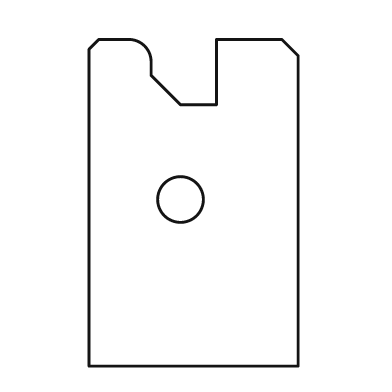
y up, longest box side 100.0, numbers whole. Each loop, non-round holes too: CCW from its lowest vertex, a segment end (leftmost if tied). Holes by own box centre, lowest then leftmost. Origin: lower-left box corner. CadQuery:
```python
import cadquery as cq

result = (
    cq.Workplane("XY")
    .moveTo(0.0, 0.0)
    .lineTo(64.0, 0.0)
    .lineTo(64.0, 95.0)
    .lineTo(59.0, 100.0)
    .lineTo(39.0, 100.0)
    .lineTo(39.0, 80.0)
    .lineTo(28.0, 80.0)
    .lineTo(19.0, 89.0)
    .lineTo(19.0, 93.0)
    .threePointArc((17.0, 98.0), (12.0, 100.0))
    .lineTo(3.0, 100.0)
    .lineTo(0.0, 97.0)
    .close()
    .moveTo(28.0, 51.0)
    .circle(7.0)
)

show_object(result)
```